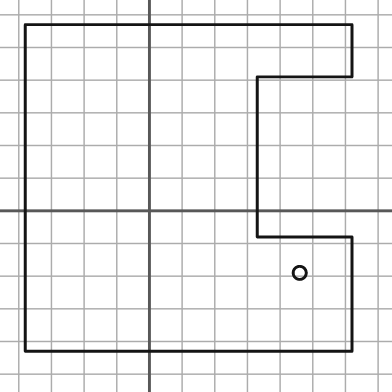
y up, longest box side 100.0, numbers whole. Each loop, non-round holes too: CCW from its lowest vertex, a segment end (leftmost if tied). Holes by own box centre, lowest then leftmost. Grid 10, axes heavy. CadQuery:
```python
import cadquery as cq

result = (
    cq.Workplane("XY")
    .moveTo(-38.0, -43.0)
    .lineTo(62.0, -43.0)
    .lineTo(62.0, -8.0)
    .lineTo(33.0, -8.0)
    .lineTo(33.0, 41.0)
    .lineTo(62.0, 41.0)
    .lineTo(62.0, 57.0)
    .lineTo(-38.0, 57.0)
    .close()
    .moveTo(46.0, -19.0)
    .circle(2.0)
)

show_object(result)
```